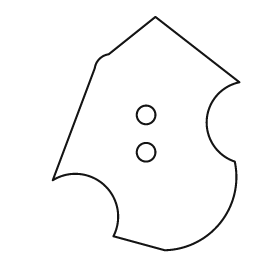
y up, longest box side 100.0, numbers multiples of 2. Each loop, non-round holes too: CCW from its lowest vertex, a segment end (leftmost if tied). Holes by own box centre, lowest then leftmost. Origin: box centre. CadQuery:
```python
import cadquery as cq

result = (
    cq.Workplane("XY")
    .moveTo(8.0, -50.0)
    .threePointArc((32.0, -38.0), (38.0, -12.0))
    .threePointArc((26.0, 6.0), (40.0, 22.0))
    .lineTo(4.0, 50.0)
    .lineTo(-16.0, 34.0)
    .threePointArc((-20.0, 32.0), (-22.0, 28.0))
    .lineTo(-40.0, -20.0)
    .threePointArc((-18.0, -22.0), (-14.0, -44.0))
    .close()
    .moveTo(0.0, -8.0)
    .circle(4.0)
    .moveTo(0.0, 8.0)
    .circle(4.0)
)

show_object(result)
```